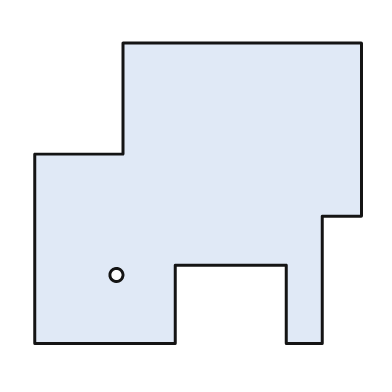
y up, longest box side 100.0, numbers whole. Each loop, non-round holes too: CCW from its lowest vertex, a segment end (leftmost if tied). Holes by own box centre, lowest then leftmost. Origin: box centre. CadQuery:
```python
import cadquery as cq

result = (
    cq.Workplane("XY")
    .moveTo(-50.0, -46.0)
    .lineTo(-7.0, -46.0)
    .lineTo(-7.0, -22.0)
    .lineTo(27.0, -22.0)
    .lineTo(27.0, -46.0)
    .lineTo(38.0, -46.0)
    .lineTo(38.0, -7.0)
    .lineTo(50.0, -7.0)
    .lineTo(50.0, 46.0)
    .lineTo(-23.0, 46.0)
    .lineTo(-23.0, 12.0)
    .lineTo(-50.0, 12.0)
    .close()
    .moveTo(-25.0, -25.0)
    .circle(2.0)
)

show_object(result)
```